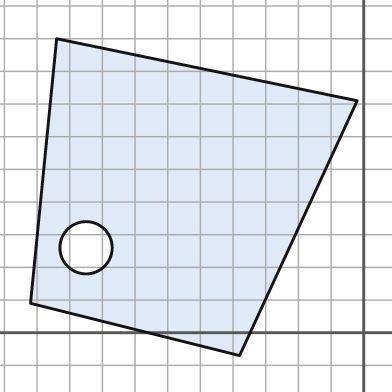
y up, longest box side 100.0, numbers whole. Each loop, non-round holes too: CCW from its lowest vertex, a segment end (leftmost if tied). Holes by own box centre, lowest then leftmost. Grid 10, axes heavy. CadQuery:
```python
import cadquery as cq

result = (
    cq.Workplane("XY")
    .moveTo(-38.0, -7.0)
    .lineTo(-2.0, 71.0)
    .lineTo(-94.0, 90.0)
    .lineTo(-102.0, 9.0)
    .close()
    .moveTo(-85.0, 26.0)
    .circle(8.0)
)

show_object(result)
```